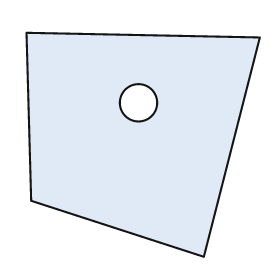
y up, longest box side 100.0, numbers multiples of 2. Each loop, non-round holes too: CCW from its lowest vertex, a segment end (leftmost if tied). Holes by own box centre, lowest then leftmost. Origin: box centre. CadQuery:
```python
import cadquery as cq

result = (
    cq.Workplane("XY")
    .moveTo(26.0, -48.0)
    .lineTo(50.0, 46.0)
    .lineTo(-50.0, 48.0)
    .lineTo(-48.0, -24.0)
    .close()
    .moveTo(-2.0, 18.0)
    .circle(8.0)
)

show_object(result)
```